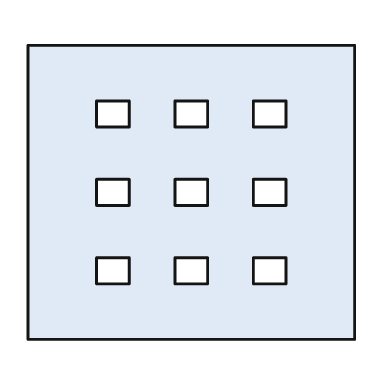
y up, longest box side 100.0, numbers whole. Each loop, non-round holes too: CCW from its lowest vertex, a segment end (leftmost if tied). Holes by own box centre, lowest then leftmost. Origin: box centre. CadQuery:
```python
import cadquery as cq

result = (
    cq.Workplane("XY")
    .moveTo(-50.0, -45.0)
    .lineTo(50.0, -45.0)
    .lineTo(50.0, 45.0)
    .lineTo(-50.0, 45.0)
    .close()
    .moveTo(-29.0, -28.0)
    .lineTo(-19.0, -28.0)
    .lineTo(-19.0, -20.0)
    .lineTo(-29.0, -20.0)
    .close()
    .moveTo(-5.0, -28.0)
    .lineTo(5.0, -28.0)
    .lineTo(5.0, -20.0)
    .lineTo(-5.0, -20.0)
    .close()
    .moveTo(19.0, -28.0)
    .lineTo(29.0, -28.0)
    .lineTo(29.0, -20.0)
    .lineTo(19.0, -20.0)
    .close()
    .moveTo(-29.0, -4.0)
    .lineTo(-19.0, -4.0)
    .lineTo(-19.0, 4.0)
    .lineTo(-29.0, 4.0)
    .close()
    .moveTo(-5.0, -4.0)
    .lineTo(5.0, -4.0)
    .lineTo(5.0, 4.0)
    .lineTo(-5.0, 4.0)
    .close()
    .moveTo(19.0, -4.0)
    .lineTo(29.0, -4.0)
    .lineTo(29.0, 4.0)
    .lineTo(19.0, 4.0)
    .close()
    .moveTo(-29.0, 20.0)
    .lineTo(-19.0, 20.0)
    .lineTo(-19.0, 28.0)
    .lineTo(-29.0, 28.0)
    .close()
    .moveTo(-5.0, 20.0)
    .lineTo(5.0, 20.0)
    .lineTo(5.0, 28.0)
    .lineTo(-5.0, 28.0)
    .close()
    .moveTo(19.0, 20.0)
    .lineTo(29.0, 20.0)
    .lineTo(29.0, 28.0)
    .lineTo(19.0, 28.0)
    .close()
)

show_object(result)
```